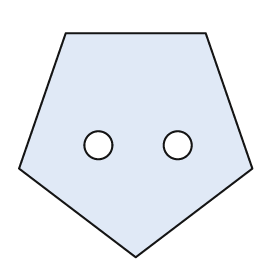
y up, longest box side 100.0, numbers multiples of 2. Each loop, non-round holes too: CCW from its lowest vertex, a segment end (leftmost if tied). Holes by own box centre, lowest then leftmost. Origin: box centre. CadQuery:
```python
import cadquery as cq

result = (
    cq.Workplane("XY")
    .moveTo(0.0, -48.0)
    .lineTo(50.0, -10.0)
    .lineTo(30.0, 48.0)
    .lineTo(-30.0, 48.0)
    .lineTo(-50.0, -10.0)
    .close()
    .moveTo(-16.0, 0.0)
    .circle(6.0)
    .moveTo(18.0, 0.0)
    .circle(6.0)
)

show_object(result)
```